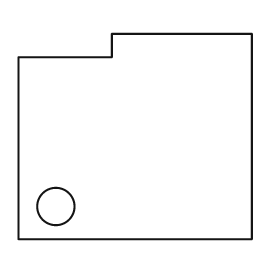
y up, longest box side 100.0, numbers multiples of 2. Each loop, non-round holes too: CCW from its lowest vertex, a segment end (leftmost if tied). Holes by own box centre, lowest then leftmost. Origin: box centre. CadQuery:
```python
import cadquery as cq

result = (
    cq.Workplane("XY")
    .moveTo(-50.0, -44.0)
    .lineTo(50.0, -44.0)
    .lineTo(50.0, 44.0)
    .lineTo(-10.0, 44.0)
    .lineTo(-10.0, 34.0)
    .lineTo(-50.0, 34.0)
    .close()
    .moveTo(-34.0, -30.0)
    .circle(8.0)
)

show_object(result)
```